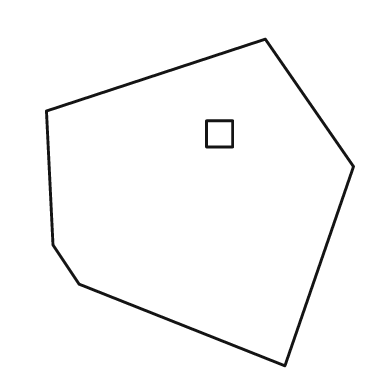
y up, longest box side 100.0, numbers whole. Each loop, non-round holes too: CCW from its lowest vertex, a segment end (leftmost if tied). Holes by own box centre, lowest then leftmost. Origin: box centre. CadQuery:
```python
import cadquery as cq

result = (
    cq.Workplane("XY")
    .moveTo(26.0, -50.0)
    .lineTo(47.0, 11.0)
    .lineTo(20.0, 50.0)
    .lineTo(-47.0, 28.0)
    .lineTo(-45.0, -13.0)
    .lineTo(-37.0, -25.0)
    .close()
    .moveTo(2.0, 17.0)
    .lineTo(10.0, 17.0)
    .lineTo(10.0, 25.0)
    .lineTo(2.0, 25.0)
    .close()
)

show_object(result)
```